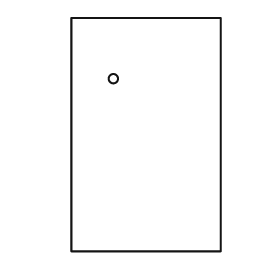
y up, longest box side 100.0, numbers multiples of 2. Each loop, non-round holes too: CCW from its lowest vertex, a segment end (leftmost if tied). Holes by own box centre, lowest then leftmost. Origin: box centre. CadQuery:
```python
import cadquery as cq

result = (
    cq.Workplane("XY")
    .moveTo(-32.0, -50.0)
    .lineTo(32.0, -50.0)
    .lineTo(32.0, 50.0)
    .lineTo(-32.0, 50.0)
    .close()
    .moveTo(-14.0, 24.0)
    .circle(2.0)
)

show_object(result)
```